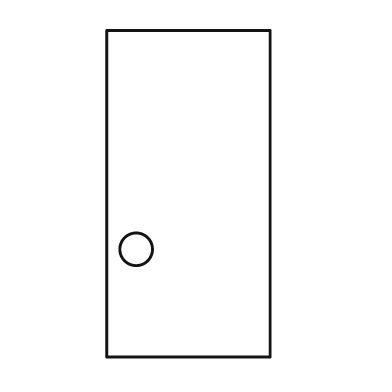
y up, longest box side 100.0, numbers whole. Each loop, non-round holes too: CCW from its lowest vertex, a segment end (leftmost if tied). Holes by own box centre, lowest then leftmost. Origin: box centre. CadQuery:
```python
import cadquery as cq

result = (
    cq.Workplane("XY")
    .moveTo(-25.0, -50.0)
    .lineTo(25.0, -50.0)
    .lineTo(25.0, 50.0)
    .lineTo(-25.0, 50.0)
    .close()
    .moveTo(-16.0, -17.0)
    .circle(5.0)
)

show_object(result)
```